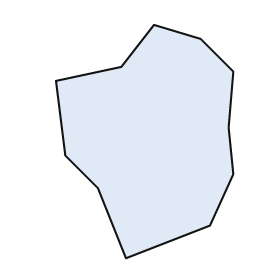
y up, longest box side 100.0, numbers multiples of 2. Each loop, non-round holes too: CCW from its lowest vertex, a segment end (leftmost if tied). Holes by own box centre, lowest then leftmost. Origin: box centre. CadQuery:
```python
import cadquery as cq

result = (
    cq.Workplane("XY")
    .moveTo(-8.0, -50.0)
    .lineTo(28.0, -36.0)
    .lineTo(38.0, -14.0)
    .lineTo(36.0, 6.0)
    .lineTo(38.0, 30.0)
    .lineTo(24.0, 44.0)
    .lineTo(4.0, 50.0)
    .lineTo(-10.0, 32.0)
    .lineTo(-38.0, 26.0)
    .lineTo(-34.0, -6.0)
    .lineTo(-20.0, -20.0)
    .close()
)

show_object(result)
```